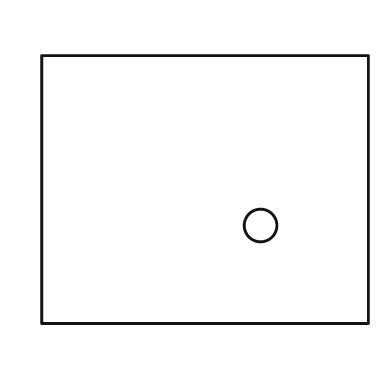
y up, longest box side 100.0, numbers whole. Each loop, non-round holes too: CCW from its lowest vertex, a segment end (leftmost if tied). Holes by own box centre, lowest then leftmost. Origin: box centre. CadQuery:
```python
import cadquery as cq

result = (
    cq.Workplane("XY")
    .moveTo(-50.0, -41.0)
    .lineTo(50.0, -41.0)
    .lineTo(50.0, 41.0)
    .lineTo(-50.0, 41.0)
    .close()
    .moveTo(17.0, -11.0)
    .circle(5.0)
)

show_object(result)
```